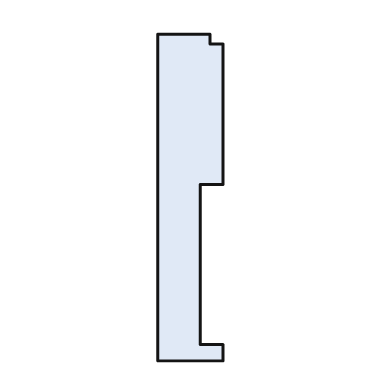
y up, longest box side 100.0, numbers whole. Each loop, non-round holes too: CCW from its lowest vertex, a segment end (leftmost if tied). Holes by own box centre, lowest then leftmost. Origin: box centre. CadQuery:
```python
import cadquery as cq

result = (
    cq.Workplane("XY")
    .moveTo(-10.0, -50.0)
    .lineTo(10.0, -50.0)
    .lineTo(10.0, -45.0)
    .lineTo(3.0, -45.0)
    .lineTo(3.0, 4.0)
    .lineTo(10.0, 4.0)
    .lineTo(10.0, 47.0)
    .lineTo(6.0, 47.0)
    .lineTo(6.0, 50.0)
    .lineTo(-10.0, 50.0)
    .close()
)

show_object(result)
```